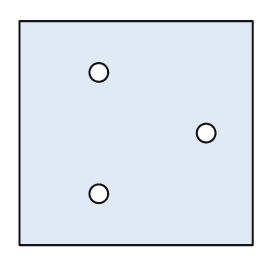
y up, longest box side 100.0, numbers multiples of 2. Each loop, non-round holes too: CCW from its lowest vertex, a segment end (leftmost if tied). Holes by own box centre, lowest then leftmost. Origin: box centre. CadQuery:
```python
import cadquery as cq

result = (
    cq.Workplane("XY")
    .moveTo(-50.0, -48.0)
    .lineTo(50.0, -48.0)
    .lineTo(50.0, 48.0)
    .lineTo(-50.0, 48.0)
    .close()
    .moveTo(-16.0, -26.0)
    .circle(4.0)
    .moveTo(30.0, 0.0)
    .circle(4.0)
    .moveTo(-16.0, 26.0)
    .circle(4.0)
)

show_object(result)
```